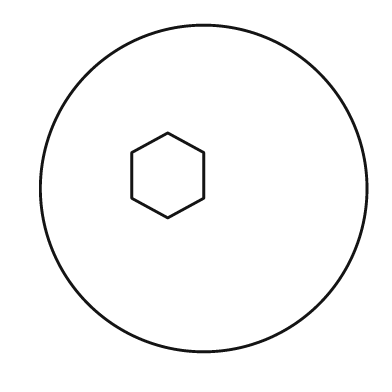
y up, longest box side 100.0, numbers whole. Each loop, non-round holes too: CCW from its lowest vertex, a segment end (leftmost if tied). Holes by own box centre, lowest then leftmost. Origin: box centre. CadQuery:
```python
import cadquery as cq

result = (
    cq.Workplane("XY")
    .moveTo(0.0, 0.0)
    .circle(50.0)
    .moveTo(-11.0, -9.0)
    .lineTo(0.0, -3.0)
    .lineTo(0.0, 11.0)
    .lineTo(-11.0, 17.0)
    .lineTo(-22.0, 11.0)
    .lineTo(-22.0, -3.0)
    .close()
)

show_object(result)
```